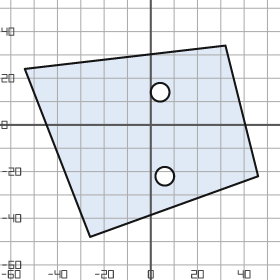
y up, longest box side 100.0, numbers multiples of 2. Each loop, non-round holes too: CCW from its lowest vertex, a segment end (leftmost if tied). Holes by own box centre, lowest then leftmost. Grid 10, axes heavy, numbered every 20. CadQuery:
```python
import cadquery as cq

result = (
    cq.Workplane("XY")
    .moveTo(-26.0, -48.0)
    .lineTo(46.0, -22.0)
    .lineTo(32.0, 34.0)
    .lineTo(-54.0, 24.0)
    .close()
    .moveTo(6.0, -22.0)
    .circle(4.0)
    .moveTo(4.0, 14.0)
    .circle(4.0)
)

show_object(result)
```